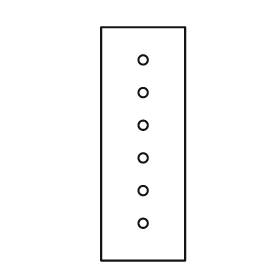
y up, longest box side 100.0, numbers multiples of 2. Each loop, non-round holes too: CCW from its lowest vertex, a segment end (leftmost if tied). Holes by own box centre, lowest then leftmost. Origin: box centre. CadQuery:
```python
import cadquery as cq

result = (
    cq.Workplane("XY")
    .moveTo(-18.0, -50.0)
    .lineTo(18.0, -50.0)
    .lineTo(18.0, 50.0)
    .lineTo(-18.0, 50.0)
    .close()
    .moveTo(0.0, -34.0)
    .circle(2.0)
    .moveTo(0.0, -20.0)
    .circle(2.0)
    .moveTo(0.0, -6.0)
    .circle(2.0)
    .moveTo(0.0, 8.0)
    .circle(2.0)
    .moveTo(0.0, 22.0)
    .circle(2.0)
    .moveTo(0.0, 36.0)
    .circle(2.0)
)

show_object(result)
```